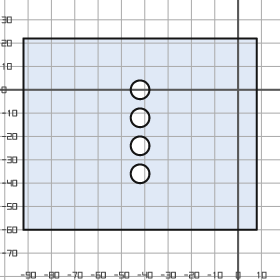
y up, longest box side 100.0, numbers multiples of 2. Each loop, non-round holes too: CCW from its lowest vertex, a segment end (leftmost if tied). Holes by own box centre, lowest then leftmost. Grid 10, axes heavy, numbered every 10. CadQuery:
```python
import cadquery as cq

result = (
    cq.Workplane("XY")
    .moveTo(-92.0, -60.0)
    .lineTo(8.0, -60.0)
    .lineTo(8.0, 22.0)
    .lineTo(-92.0, 22.0)
    .close()
    .moveTo(-42.0, -36.0)
    .circle(4.0)
    .moveTo(-42.0, -24.0)
    .circle(4.0)
    .moveTo(-42.0, -12.0)
    .circle(4.0)
    .moveTo(-42.0, 0.0)
    .circle(4.0)
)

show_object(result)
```